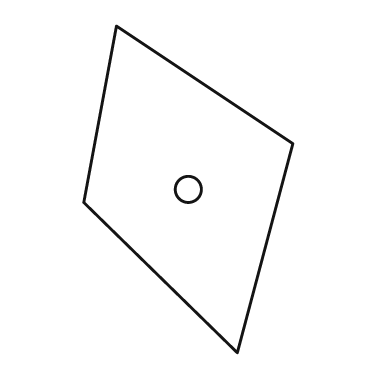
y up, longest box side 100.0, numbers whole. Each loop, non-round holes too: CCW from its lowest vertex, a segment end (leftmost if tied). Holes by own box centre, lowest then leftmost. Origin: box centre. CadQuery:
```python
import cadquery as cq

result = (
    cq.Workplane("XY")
    .moveTo(15.0, -50.0)
    .lineTo(32.0, 14.0)
    .lineTo(-22.0, 50.0)
    .lineTo(-32.0, -4.0)
    .close()
    .moveTo(0.0, 0.0)
    .circle(4.0)
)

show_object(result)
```